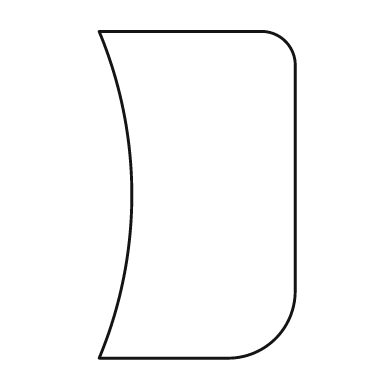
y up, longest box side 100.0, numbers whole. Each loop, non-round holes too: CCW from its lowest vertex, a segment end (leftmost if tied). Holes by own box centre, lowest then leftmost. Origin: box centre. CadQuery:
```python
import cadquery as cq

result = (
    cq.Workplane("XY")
    .moveTo(-30.0, -50.0)
    .lineTo(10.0, -50.0)
    .threePointArc((24.0, -44.0), (30.0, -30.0))
    .lineTo(30.0, 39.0)
    .threePointArc((27.0, 47.0), (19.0, 50.0))
    .lineTo(-30.0, 50.0)
    .threePointArc((-20.0, 0.0), (-30.0, -50.0))
    .close()
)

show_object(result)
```